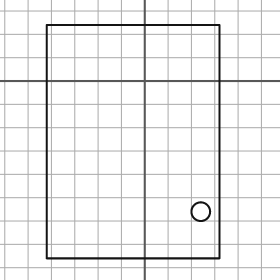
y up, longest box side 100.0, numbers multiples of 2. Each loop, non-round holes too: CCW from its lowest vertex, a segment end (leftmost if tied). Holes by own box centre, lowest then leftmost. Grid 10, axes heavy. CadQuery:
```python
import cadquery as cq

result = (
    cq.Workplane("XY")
    .moveTo(-42.0, -76.0)
    .lineTo(32.0, -76.0)
    .lineTo(32.0, 24.0)
    .lineTo(-42.0, 24.0)
    .close()
    .moveTo(24.0, -56.0)
    .circle(4.0)
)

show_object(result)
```